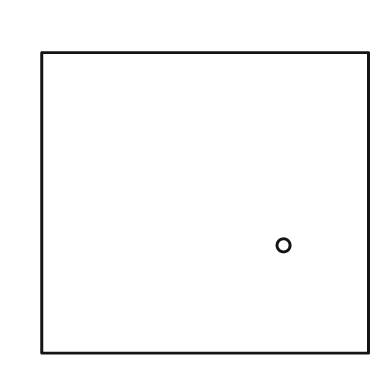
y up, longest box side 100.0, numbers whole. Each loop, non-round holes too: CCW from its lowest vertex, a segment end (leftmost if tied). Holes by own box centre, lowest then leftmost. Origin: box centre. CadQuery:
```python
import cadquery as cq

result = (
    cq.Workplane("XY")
    .moveTo(-50.0, -46.0)
    .lineTo(50.0, -46.0)
    .lineTo(50.0, 46.0)
    .lineTo(-50.0, 46.0)
    .close()
    .moveTo(24.0, -13.0)
    .circle(2.0)
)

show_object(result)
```